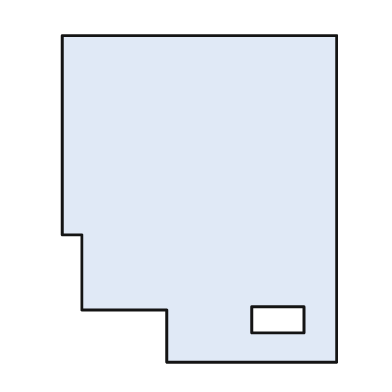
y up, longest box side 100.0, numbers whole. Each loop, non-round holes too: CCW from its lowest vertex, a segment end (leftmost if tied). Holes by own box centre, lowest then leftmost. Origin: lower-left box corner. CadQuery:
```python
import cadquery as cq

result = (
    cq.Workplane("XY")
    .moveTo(32.0, 0.0)
    .lineTo(84.0, 0.0)
    .lineTo(84.0, 100.0)
    .lineTo(0.0, 100.0)
    .lineTo(0.0, 39.0)
    .lineTo(6.0, 39.0)
    .lineTo(6.0, 16.0)
    .lineTo(32.0, 16.0)
    .close()
    .moveTo(58.0, 9.0)
    .lineTo(74.0, 9.0)
    .lineTo(74.0, 17.0)
    .lineTo(58.0, 17.0)
    .close()
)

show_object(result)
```